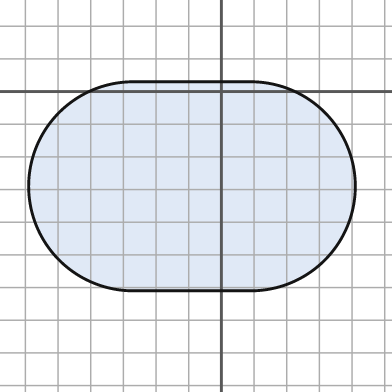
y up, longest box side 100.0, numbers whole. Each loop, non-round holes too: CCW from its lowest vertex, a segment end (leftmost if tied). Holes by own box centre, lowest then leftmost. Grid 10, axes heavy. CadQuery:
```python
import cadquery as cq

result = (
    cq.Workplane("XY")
    .moveTo(-27.0, -61.0)
    .lineTo(9.0, -61.0)
    .threePointArc((41.0, -29.0), (9.0, 3.0))
    .lineTo(-27.0, 3.0)
    .threePointArc((-59.0, -29.0), (-27.0, -61.0))
    .close()
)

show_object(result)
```